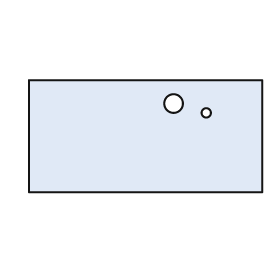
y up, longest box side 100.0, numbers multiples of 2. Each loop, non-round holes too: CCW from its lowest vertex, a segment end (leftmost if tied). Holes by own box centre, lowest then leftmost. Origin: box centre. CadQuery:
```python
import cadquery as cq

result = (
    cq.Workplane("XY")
    .moveTo(-50.0, -24.0)
    .lineTo(50.0, -24.0)
    .lineTo(50.0, 24.0)
    .lineTo(-50.0, 24.0)
    .close()
    .moveTo(26.0, 10.0)
    .circle(2.0)
    .moveTo(12.0, 14.0)
    .circle(4.0)
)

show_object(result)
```